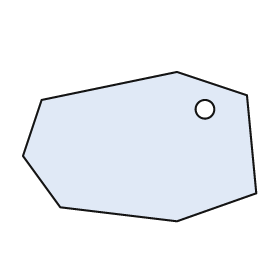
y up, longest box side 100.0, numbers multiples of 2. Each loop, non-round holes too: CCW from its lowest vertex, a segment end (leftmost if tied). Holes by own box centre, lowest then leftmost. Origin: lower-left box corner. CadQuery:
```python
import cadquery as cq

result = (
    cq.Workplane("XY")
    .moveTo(66.0, 0.0)
    .lineTo(100.0, 12.0)
    .lineTo(96.0, 54.0)
    .lineTo(66.0, 64.0)
    .lineTo(8.0, 52.0)
    .lineTo(0.0, 28.0)
    .lineTo(16.0, 6.0)
    .close()
    .moveTo(78.0, 48.0)
    .circle(4.0)
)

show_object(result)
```